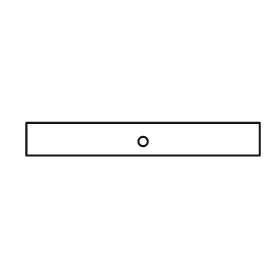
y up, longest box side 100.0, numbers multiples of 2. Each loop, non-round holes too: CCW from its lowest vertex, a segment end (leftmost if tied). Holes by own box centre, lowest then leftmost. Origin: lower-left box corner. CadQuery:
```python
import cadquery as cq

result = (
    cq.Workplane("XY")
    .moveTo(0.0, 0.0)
    .lineTo(100.0, 0.0)
    .lineTo(100.0, 14.0)
    .lineTo(0.0, 14.0)
    .close()
    .moveTo(50.0, 6.0)
    .circle(2.0)
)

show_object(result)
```